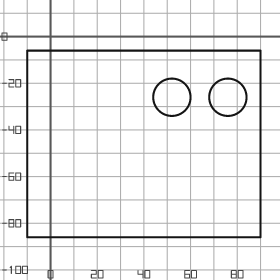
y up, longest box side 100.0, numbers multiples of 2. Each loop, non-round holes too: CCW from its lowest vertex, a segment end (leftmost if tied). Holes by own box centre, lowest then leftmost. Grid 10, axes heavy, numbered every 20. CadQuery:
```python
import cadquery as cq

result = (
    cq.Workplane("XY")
    .moveTo(-10.0, -86.0)
    .lineTo(90.0, -86.0)
    .lineTo(90.0, -6.0)
    .lineTo(-10.0, -6.0)
    .close()
    .moveTo(52.0, -26.0)
    .circle(8.0)
    .moveTo(76.0, -26.0)
    .circle(8.0)
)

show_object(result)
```